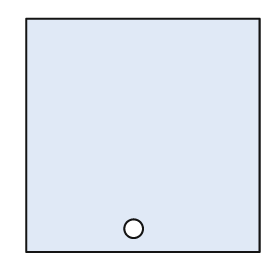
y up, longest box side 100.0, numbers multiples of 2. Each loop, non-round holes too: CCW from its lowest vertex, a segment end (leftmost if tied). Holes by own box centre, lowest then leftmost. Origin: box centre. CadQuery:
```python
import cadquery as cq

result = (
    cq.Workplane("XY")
    .moveTo(-50.0, -50.0)
    .lineTo(50.0, -50.0)
    .lineTo(50.0, 50.0)
    .lineTo(-50.0, 50.0)
    .close()
    .moveTo(-4.0, -40.0)
    .circle(4.0)
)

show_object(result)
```